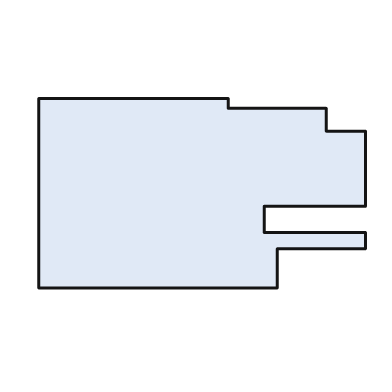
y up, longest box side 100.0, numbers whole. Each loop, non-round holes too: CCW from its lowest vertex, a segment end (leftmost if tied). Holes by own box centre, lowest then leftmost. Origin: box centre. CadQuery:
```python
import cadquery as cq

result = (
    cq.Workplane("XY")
    .moveTo(-50.0, -29.0)
    .lineTo(23.0, -29.0)
    .lineTo(23.0, -17.0)
    .lineTo(50.0, -17.0)
    .lineTo(50.0, -12.0)
    .lineTo(19.0, -12.0)
    .lineTo(19.0, -4.0)
    .lineTo(50.0, -4.0)
    .lineTo(50.0, 19.0)
    .lineTo(38.0, 19.0)
    .lineTo(38.0, 26.0)
    .lineTo(8.0, 26.0)
    .lineTo(8.0, 29.0)
    .lineTo(-50.0, 29.0)
    .close()
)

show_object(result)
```